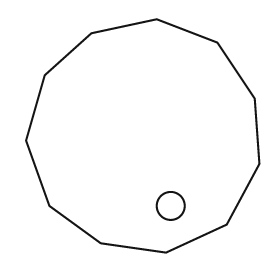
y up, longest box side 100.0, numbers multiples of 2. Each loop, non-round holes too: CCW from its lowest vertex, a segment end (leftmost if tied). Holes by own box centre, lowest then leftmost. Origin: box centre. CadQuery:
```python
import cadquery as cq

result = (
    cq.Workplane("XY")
    .moveTo(10.0, -50.0)
    .lineTo(36.0, -38.0)
    .lineTo(50.0, -12.0)
    .lineTo(48.0, 16.0)
    .lineTo(32.0, 40.0)
    .lineTo(6.0, 50.0)
    .lineTo(-22.0, 44.0)
    .lineTo(-42.0, 26.0)
    .lineTo(-50.0, -2.0)
    .lineTo(-40.0, -30.0)
    .lineTo(-18.0, -46.0)
    .close()
    .moveTo(12.0, -30.0)
    .circle(6.0)
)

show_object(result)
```